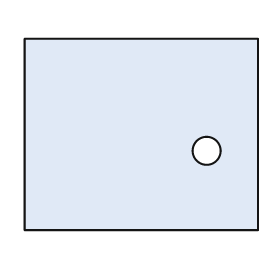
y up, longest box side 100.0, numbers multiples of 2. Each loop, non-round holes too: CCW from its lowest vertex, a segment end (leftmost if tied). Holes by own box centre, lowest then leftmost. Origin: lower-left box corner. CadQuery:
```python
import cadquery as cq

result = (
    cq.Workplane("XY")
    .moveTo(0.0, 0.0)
    .lineTo(100.0, 0.0)
    .lineTo(100.0, 82.0)
    .lineTo(0.0, 82.0)
    .close()
    .moveTo(78.0, 34.0)
    .circle(6.0)
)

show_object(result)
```